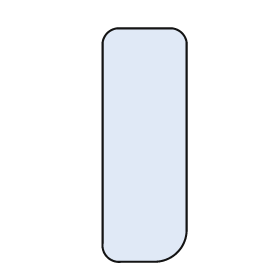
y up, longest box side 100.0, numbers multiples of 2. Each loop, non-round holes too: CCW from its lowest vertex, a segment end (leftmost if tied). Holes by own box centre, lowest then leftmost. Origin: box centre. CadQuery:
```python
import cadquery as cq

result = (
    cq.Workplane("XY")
    .moveTo(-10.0, -50.0)
    .lineTo(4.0, -50.0)
    .threePointArc((14.0, -46.0), (18.0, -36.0))
    .lineTo(18.0, 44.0)
    .threePointArc((16.0, 48.0), (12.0, 50.0))
    .lineTo(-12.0, 50.0)
    .threePointArc((-16.0, 48.0), (-18.0, 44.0))
    .lineTo(-18.0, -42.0)
    .threePointArc((-16.0, -48.0), (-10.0, -50.0))
    .close()
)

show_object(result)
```